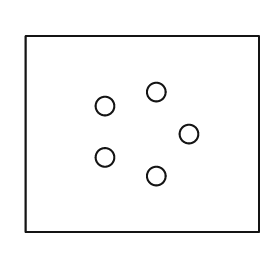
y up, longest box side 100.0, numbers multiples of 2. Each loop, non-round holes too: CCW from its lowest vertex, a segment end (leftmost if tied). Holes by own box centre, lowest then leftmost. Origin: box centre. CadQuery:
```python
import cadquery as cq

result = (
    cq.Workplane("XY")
    .moveTo(-50.0, -42.0)
    .lineTo(50.0, -42.0)
    .lineTo(50.0, 42.0)
    .lineTo(-50.0, 42.0)
    .close()
    .moveTo(6.0, -18.0)
    .circle(4.0)
    .moveTo(-16.0, -10.0)
    .circle(4.0)
    .moveTo(20.0, 0.0)
    .circle(4.0)
    .moveTo(-16.0, 12.0)
    .circle(4.0)
    .moveTo(6.0, 18.0)
    .circle(4.0)
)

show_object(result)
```